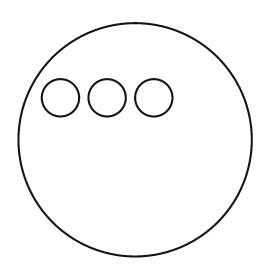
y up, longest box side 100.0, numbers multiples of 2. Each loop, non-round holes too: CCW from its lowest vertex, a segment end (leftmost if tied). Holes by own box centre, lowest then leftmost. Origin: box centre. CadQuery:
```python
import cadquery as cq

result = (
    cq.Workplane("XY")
    .moveTo(0.0, 0.0)
    .circle(50.0)
    .moveTo(-32.0, 18.0)
    .circle(8.0)
    .moveTo(-12.0, 18.0)
    .circle(8.0)
    .moveTo(8.0, 18.0)
    .circle(8.0)
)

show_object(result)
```